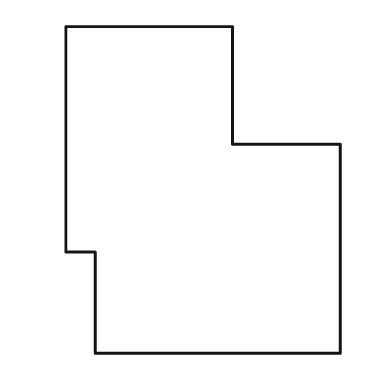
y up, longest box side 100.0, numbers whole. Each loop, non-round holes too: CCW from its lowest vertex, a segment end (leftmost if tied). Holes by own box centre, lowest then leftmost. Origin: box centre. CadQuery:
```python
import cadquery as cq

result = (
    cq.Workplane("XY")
    .moveTo(-33.0, -50.0)
    .lineTo(42.0, -50.0)
    .lineTo(42.0, 14.0)
    .lineTo(9.0, 14.0)
    .lineTo(9.0, 50.0)
    .lineTo(-42.0, 50.0)
    .lineTo(-42.0, -19.0)
    .lineTo(-33.0, -19.0)
    .close()
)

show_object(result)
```